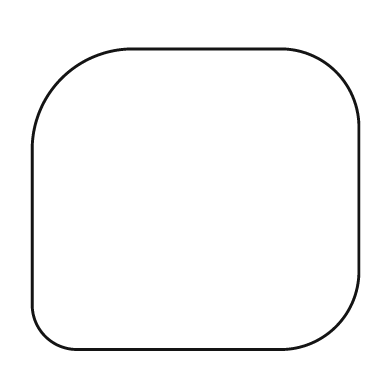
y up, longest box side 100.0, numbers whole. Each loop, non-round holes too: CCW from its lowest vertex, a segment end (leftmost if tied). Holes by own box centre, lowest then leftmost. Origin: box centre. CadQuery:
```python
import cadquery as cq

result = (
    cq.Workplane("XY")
    .moveTo(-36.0, -46.0)
    .lineTo(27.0, -46.0)
    .threePointArc((43.0, -39.0), (50.0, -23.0))
    .lineTo(50.0, 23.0)
    .threePointArc((43.0, 39.0), (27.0, 46.0))
    .lineTo(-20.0, 46.0)
    .threePointArc((-41.0, 37.0), (-50.0, 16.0))
    .lineTo(-50.0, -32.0)
    .threePointArc((-46.0, -42.0), (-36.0, -46.0))
    .close()
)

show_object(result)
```